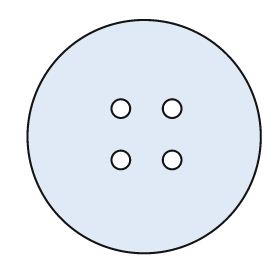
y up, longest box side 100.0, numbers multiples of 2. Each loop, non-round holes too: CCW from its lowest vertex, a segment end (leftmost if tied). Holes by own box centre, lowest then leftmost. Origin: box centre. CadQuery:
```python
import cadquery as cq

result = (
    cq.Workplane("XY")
    .moveTo(0.0, 0.0)
    .circle(50.0)
    .moveTo(-10.0, -10.0)
    .circle(4.0)
    .moveTo(12.0, -10.0)
    .circle(4.0)
    .moveTo(-10.0, 12.0)
    .circle(4.0)
    .moveTo(12.0, 12.0)
    .circle(4.0)
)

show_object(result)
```